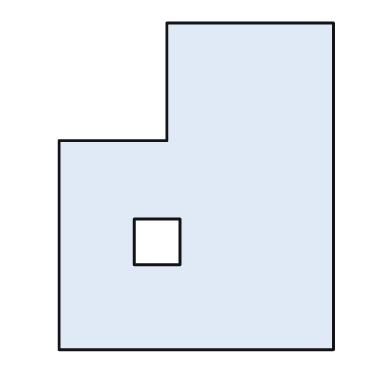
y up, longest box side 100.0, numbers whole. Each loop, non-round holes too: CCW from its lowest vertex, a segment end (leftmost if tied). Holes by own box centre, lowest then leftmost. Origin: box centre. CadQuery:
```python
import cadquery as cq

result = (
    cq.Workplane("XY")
    .moveTo(-42.0, -50.0)
    .lineTo(42.0, -50.0)
    .lineTo(42.0, 50.0)
    .lineTo(-9.0, 50.0)
    .lineTo(-9.0, 14.0)
    .lineTo(-42.0, 14.0)
    .close()
    .moveTo(-19.0, -24.0)
    .lineTo(-5.0, -24.0)
    .lineTo(-5.0, -10.0)
    .lineTo(-19.0, -10.0)
    .close()
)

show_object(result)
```